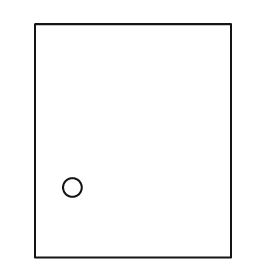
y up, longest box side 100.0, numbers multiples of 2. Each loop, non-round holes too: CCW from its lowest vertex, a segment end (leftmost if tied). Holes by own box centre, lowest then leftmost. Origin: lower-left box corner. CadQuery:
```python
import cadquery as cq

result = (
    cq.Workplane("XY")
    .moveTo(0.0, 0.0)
    .lineTo(84.0, 0.0)
    .lineTo(84.0, 100.0)
    .lineTo(0.0, 100.0)
    .close()
    .moveTo(16.0, 30.0)
    .circle(4.0)
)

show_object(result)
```